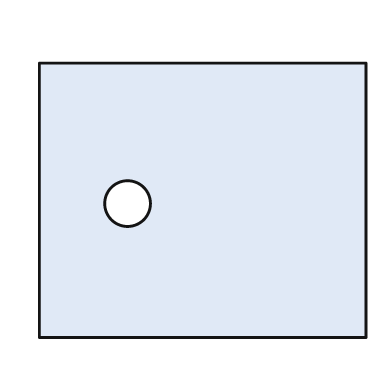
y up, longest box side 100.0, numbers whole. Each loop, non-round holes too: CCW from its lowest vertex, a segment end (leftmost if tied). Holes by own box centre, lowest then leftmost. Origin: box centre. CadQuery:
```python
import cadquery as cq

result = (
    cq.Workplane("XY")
    .moveTo(-50.0, -42.0)
    .lineTo(50.0, -42.0)
    .lineTo(50.0, 42.0)
    .lineTo(-50.0, 42.0)
    .close()
    .moveTo(-23.0, -1.0)
    .circle(7.0)
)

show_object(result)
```